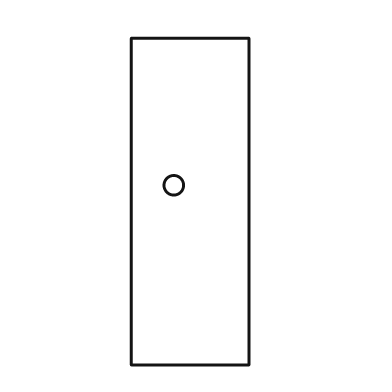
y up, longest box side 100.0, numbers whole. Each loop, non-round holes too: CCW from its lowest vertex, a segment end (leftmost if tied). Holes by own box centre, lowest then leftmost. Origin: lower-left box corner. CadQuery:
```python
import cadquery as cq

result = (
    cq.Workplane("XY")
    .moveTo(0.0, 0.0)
    .lineTo(36.0, 0.0)
    .lineTo(36.0, 100.0)
    .lineTo(0.0, 100.0)
    .close()
    .moveTo(13.0, 55.0)
    .circle(3.0)
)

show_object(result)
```